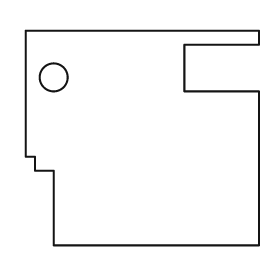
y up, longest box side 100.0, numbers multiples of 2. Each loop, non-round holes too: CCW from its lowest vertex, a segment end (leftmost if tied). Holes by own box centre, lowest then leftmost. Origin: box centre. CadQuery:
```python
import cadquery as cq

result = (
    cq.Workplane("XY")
    .moveTo(-38.0, -46.0)
    .lineTo(50.0, -46.0)
    .lineTo(50.0, 20.0)
    .lineTo(18.0, 20.0)
    .lineTo(18.0, 40.0)
    .lineTo(50.0, 40.0)
    .lineTo(50.0, 46.0)
    .lineTo(-50.0, 46.0)
    .lineTo(-50.0, -8.0)
    .lineTo(-46.0, -8.0)
    .lineTo(-46.0, -14.0)
    .lineTo(-38.0, -14.0)
    .close()
    .moveTo(-38.0, 26.0)
    .circle(6.0)
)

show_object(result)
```